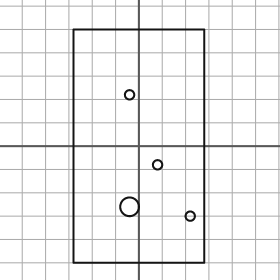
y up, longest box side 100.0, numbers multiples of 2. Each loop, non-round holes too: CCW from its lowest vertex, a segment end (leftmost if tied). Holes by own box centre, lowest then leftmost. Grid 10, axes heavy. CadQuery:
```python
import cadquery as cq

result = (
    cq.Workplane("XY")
    .moveTo(-28.0, -50.0)
    .lineTo(28.0, -50.0)
    .lineTo(28.0, 50.0)
    .lineTo(-28.0, 50.0)
    .close()
    .moveTo(22.0, -30.0)
    .circle(2.0)
    .moveTo(-4.0, -26.0)
    .circle(4.0)
    .moveTo(8.0, -8.0)
    .circle(2.0)
    .moveTo(-4.0, 22.0)
    .circle(2.0)
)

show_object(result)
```